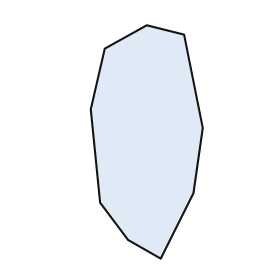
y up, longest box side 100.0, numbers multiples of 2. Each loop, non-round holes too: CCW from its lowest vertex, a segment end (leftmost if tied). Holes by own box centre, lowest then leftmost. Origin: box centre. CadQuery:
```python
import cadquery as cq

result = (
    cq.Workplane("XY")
    .moveTo(6.0, -50.0)
    .lineTo(20.0, -22.0)
    .lineTo(24.0, 6.0)
    .lineTo(16.0, 46.0)
    .lineTo(0.0, 50.0)
    .lineTo(-18.0, 40.0)
    .lineTo(-24.0, 14.0)
    .lineTo(-20.0, -26.0)
    .lineTo(-8.0, -42.0)
    .close()
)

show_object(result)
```